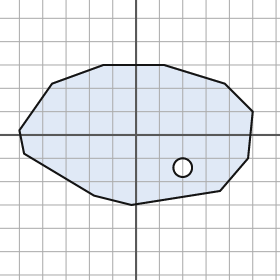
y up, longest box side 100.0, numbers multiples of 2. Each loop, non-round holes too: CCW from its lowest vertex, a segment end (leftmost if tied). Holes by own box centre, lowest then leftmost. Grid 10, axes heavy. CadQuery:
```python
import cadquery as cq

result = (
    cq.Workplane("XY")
    .moveTo(-2.0, -30.0)
    .lineTo(36.0, -24.0)
    .lineTo(48.0, -10.0)
    .lineTo(50.0, 10.0)
    .lineTo(38.0, 22.0)
    .lineTo(12.0, 30.0)
    .lineTo(-14.0, 30.0)
    .lineTo(-36.0, 22.0)
    .lineTo(-50.0, 2.0)
    .lineTo(-48.0, -8.0)
    .lineTo(-18.0, -26.0)
    .close()
    .moveTo(20.0, -14.0)
    .circle(4.0)
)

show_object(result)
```